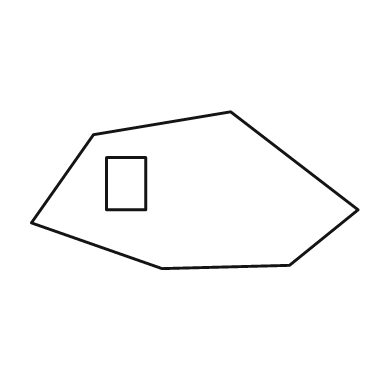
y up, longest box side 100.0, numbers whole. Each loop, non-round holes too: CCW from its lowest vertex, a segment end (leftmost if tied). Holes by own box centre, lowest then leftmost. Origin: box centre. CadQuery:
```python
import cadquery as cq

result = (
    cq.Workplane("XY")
    .moveTo(-10.0, -24.0)
    .lineTo(29.0, -23.0)
    .lineTo(50.0, -6.0)
    .lineTo(11.0, 24.0)
    .lineTo(-31.0, 17.0)
    .lineTo(-50.0, -10.0)
    .close()
    .moveTo(-27.0, -6.0)
    .lineTo(-15.0, -6.0)
    .lineTo(-15.0, 10.0)
    .lineTo(-27.0, 10.0)
    .close()
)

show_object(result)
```